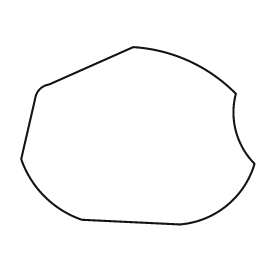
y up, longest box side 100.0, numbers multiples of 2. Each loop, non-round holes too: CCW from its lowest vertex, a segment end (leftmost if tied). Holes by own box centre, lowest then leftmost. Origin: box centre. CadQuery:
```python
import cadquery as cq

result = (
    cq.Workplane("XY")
    .moveTo(18.0, -38.0)
    .threePointArc((38.0, -30.0), (50.0, -12.0))
    .threePointArc((42.0, 2.0), (42.0, 18.0))
    .threePointArc((22.0, 32.0), (-2.0, 38.0))
    .lineTo(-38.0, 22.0)
    .threePointArc((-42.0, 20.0), (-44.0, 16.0))
    .lineTo(-50.0, -10.0)
    .threePointArc((-40.0, -26.0), (-24.0, -36.0))
    .close()
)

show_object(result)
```